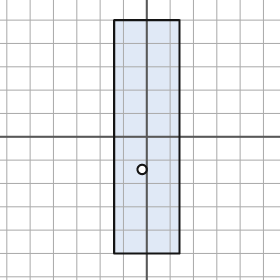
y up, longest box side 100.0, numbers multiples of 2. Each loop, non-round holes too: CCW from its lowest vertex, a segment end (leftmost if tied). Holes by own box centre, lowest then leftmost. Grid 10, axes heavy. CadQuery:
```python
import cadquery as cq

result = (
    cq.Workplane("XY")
    .moveTo(-14.0, -50.0)
    .lineTo(14.0, -50.0)
    .lineTo(14.0, 50.0)
    .lineTo(-14.0, 50.0)
    .close()
    .moveTo(-2.0, -14.0)
    .circle(2.0)
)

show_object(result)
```